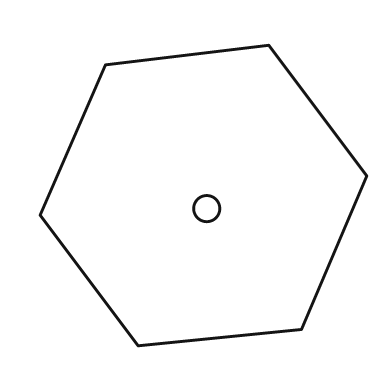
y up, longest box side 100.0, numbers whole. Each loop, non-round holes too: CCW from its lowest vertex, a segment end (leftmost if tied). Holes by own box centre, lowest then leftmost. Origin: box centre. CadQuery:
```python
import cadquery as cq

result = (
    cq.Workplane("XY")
    .moveTo(-20.0, -46.0)
    .lineTo(30.0, -41.0)
    .lineTo(50.0, 6.0)
    .lineTo(20.0, 46.0)
    .lineTo(-30.0, 40.0)
    .lineTo(-50.0, -6.0)
    .close()
    .moveTo(1.0, -4.0)
    .circle(4.0)
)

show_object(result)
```